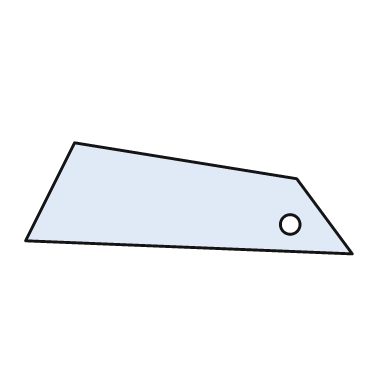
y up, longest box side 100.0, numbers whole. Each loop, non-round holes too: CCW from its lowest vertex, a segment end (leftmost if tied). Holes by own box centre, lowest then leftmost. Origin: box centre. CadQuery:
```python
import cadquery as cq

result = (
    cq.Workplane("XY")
    .moveTo(50.0, -17.0)
    .lineTo(33.0, 6.0)
    .lineTo(-35.0, 17.0)
    .lineTo(-50.0, -13.0)
    .close()
    .moveTo(31.0, -8.0)
    .circle(3.0)
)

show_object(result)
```